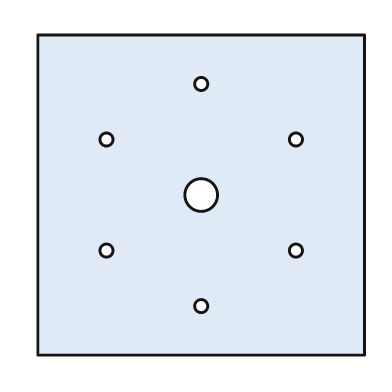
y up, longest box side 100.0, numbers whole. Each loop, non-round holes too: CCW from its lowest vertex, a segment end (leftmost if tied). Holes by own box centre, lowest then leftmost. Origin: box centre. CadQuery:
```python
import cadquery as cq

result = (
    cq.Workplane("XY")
    .moveTo(-50.0, -49.0)
    .lineTo(50.0, -49.0)
    .lineTo(50.0, 49.0)
    .lineTo(-50.0, 49.0)
    .close()
    .moveTo(0.0, -34.0)
    .circle(2.0)
    .moveTo(-29.0, -17.0)
    .circle(2.0)
    .moveTo(29.0, -17.0)
    .circle(2.0)
    .moveTo(0.0, 0.0)
    .circle(5.0)
    .moveTo(-29.0, 17.0)
    .circle(2.0)
    .moveTo(29.0, 17.0)
    .circle(2.0)
    .moveTo(0.0, 34.0)
    .circle(2.0)
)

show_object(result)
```